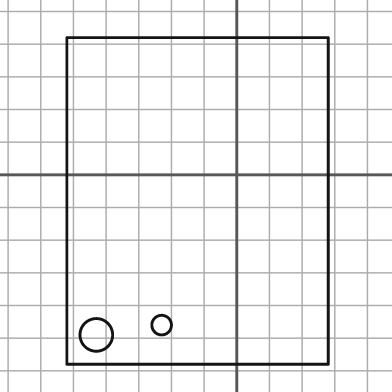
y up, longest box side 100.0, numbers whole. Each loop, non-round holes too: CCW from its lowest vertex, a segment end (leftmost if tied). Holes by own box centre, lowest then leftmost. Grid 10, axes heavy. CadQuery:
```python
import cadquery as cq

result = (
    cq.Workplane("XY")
    .moveTo(-52.0, -58.0)
    .lineTo(28.0, -58.0)
    .lineTo(28.0, 42.0)
    .lineTo(-52.0, 42.0)
    .close()
    .moveTo(-43.0, -49.0)
    .circle(5.0)
    .moveTo(-23.0, -46.0)
    .circle(3.0)
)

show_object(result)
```